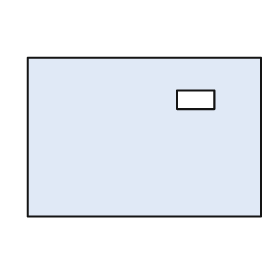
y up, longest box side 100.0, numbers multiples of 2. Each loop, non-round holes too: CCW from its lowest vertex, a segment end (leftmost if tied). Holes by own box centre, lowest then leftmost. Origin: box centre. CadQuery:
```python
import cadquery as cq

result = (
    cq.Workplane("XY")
    .moveTo(-50.0, -34.0)
    .lineTo(50.0, -34.0)
    .lineTo(50.0, 34.0)
    .lineTo(-50.0, 34.0)
    .close()
    .moveTo(14.0, 12.0)
    .lineTo(30.0, 12.0)
    .lineTo(30.0, 20.0)
    .lineTo(14.0, 20.0)
    .close()
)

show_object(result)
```